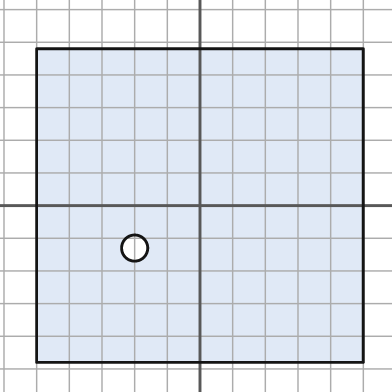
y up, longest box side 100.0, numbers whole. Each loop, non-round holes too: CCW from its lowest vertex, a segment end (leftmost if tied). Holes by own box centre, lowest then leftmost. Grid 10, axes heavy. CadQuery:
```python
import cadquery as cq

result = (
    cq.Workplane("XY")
    .moveTo(-50.0, -48.0)
    .lineTo(50.0, -48.0)
    .lineTo(50.0, 48.0)
    .lineTo(-50.0, 48.0)
    .close()
    .moveTo(-20.0, -13.0)
    .circle(4.0)
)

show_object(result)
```